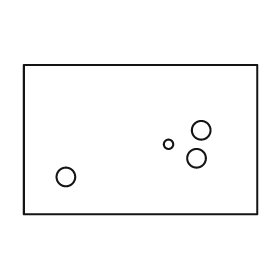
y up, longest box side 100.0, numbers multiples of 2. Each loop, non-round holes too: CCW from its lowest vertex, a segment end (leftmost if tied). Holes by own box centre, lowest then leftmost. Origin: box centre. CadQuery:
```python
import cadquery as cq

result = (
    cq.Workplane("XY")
    .moveTo(-50.0, -32.0)
    .lineTo(50.0, -32.0)
    .lineTo(50.0, 32.0)
    .lineTo(-50.0, 32.0)
    .close()
    .moveTo(-32.0, -16.0)
    .circle(4.0)
    .moveTo(24.0, -8.0)
    .circle(4.0)
    .moveTo(12.0, -2.0)
    .circle(2.0)
    .moveTo(26.0, 4.0)
    .circle(4.0)
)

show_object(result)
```